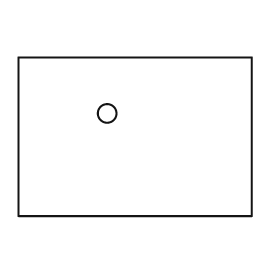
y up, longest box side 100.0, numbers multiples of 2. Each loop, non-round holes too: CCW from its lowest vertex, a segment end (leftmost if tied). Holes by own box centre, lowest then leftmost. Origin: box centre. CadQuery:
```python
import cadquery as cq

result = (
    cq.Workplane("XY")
    .moveTo(-50.0, -34.0)
    .lineTo(50.0, -34.0)
    .lineTo(50.0, 34.0)
    .lineTo(-50.0, 34.0)
    .close()
    .moveTo(-12.0, 10.0)
    .circle(4.0)
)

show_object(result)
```